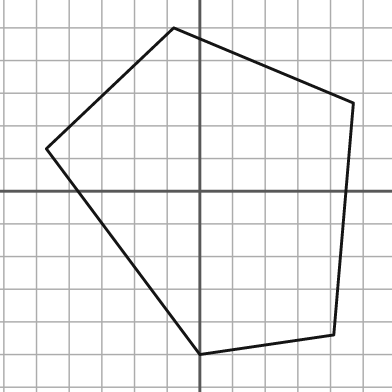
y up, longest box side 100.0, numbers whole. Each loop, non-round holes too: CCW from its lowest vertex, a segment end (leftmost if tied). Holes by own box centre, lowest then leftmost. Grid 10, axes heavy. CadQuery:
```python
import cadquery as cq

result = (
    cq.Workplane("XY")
    .moveTo(0.0, -50.0)
    .lineTo(41.0, -44.0)
    .lineTo(47.0, 27.0)
    .lineTo(-8.0, 50.0)
    .lineTo(-47.0, 13.0)
    .close()
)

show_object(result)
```